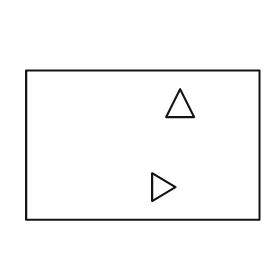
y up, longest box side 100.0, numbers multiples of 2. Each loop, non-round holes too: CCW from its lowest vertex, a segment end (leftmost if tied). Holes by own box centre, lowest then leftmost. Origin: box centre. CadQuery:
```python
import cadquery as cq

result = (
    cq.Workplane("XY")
    .moveTo(-50.0, -32.0)
    .lineTo(50.0, -32.0)
    .lineTo(50.0, 32.0)
    .lineTo(-50.0, 32.0)
    .close()
    .moveTo(4.0, -24.0)
    .lineTo(14.0, -18.0)
    .lineTo(4.0, -12.0)
    .close()
    .moveTo(10.0, 12.0)
    .lineTo(22.0, 12.0)
    .lineTo(16.0, 24.0)
    .close()
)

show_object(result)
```